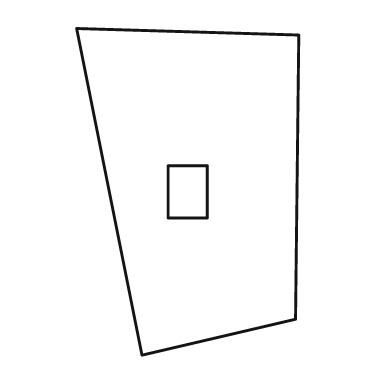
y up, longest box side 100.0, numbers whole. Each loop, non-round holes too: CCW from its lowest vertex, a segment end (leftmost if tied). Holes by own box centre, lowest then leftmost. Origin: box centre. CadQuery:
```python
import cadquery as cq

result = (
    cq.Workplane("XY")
    .moveTo(-14.0, -50.0)
    .lineTo(33.0, -39.0)
    .lineTo(34.0, 48.0)
    .lineTo(-34.0, 50.0)
    .close()
    .moveTo(-6.0, -8.0)
    .lineTo(6.0, -8.0)
    .lineTo(6.0, 8.0)
    .lineTo(-6.0, 8.0)
    .close()
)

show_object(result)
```